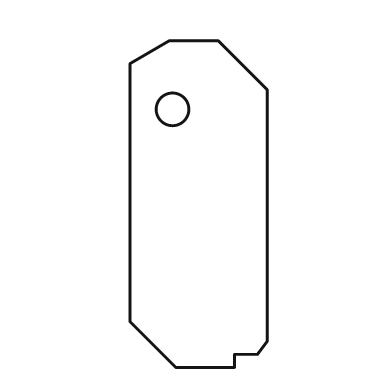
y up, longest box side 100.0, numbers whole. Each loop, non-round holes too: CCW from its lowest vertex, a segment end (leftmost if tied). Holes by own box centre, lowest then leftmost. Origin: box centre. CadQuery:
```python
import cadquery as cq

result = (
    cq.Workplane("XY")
    .moveTo(-7.0, -50.0)
    .lineTo(11.0, -50.0)
    .lineTo(11.0, -46.0)
    .lineTo(18.0, -46.0)
    .lineTo(21.0, -42.0)
    .lineTo(21.0, 35.0)
    .lineTo(6.0, 50.0)
    .lineTo(-9.0, 50.0)
    .lineTo(-21.0, 43.0)
    .lineTo(-21.0, -36.0)
    .close()
    .moveTo(-8.0, 29.0)
    .circle(5.0)
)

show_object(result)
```